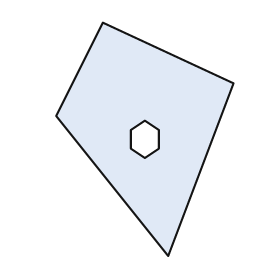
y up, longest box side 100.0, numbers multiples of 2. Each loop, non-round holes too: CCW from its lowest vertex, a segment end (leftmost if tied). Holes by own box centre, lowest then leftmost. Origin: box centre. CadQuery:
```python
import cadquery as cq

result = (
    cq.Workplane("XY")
    .moveTo(10.0, -50.0)
    .lineTo(38.0, 24.0)
    .lineTo(-18.0, 50.0)
    .lineTo(-38.0, 10.0)
    .close()
    .moveTo(0.0, -8.0)
    .lineTo(6.0, -4.0)
    .lineTo(6.0, 4.0)
    .lineTo(0.0, 8.0)
    .lineTo(-6.0, 4.0)
    .lineTo(-6.0, -4.0)
    .close()
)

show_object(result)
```